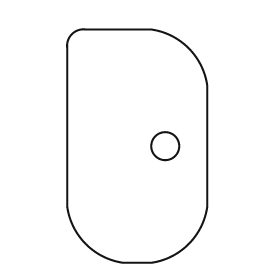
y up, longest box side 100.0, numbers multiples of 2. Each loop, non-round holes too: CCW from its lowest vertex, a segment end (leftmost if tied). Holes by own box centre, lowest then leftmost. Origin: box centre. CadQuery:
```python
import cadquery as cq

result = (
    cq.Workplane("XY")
    .moveTo(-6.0, -50.0)
    .lineTo(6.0, -50.0)
    .threePointArc((22.0, -42.0), (30.0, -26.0))
    .lineTo(30.0, 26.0)
    .threePointArc((22.0, 42.0), (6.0, 50.0))
    .lineTo(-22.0, 50.0)
    .threePointArc((-28.0, 48.0), (-30.0, 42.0))
    .lineTo(-30.0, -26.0)
    .threePointArc((-22.0, -42.0), (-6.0, -50.0))
    .close()
    .moveTo(12.0, 0.0)
    .circle(6.0)
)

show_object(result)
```